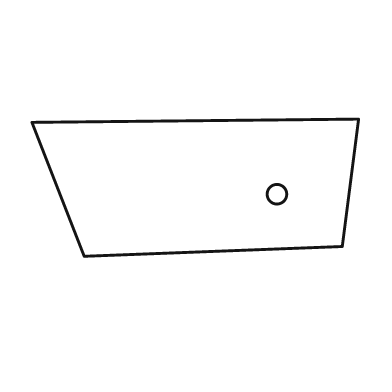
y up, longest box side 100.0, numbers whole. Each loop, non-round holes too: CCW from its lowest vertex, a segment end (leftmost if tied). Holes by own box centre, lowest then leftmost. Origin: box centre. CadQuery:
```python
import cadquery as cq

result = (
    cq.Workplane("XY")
    .moveTo(-34.0, -21.0)
    .lineTo(45.0, -18.0)
    .lineTo(50.0, 21.0)
    .lineTo(-50.0, 20.0)
    .close()
    .moveTo(25.0, -2.0)
    .circle(3.0)
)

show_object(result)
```